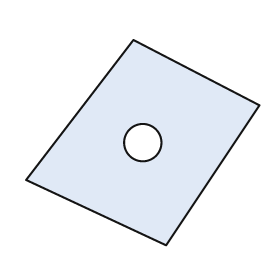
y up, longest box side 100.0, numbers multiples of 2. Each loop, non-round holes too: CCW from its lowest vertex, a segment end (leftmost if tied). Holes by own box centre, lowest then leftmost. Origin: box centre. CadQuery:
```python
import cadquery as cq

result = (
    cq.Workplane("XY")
    .moveTo(10.0, -44.0)
    .lineTo(50.0, 16.0)
    .lineTo(-4.0, 44.0)
    .lineTo(-50.0, -16.0)
    .close()
    .moveTo(0.0, 0.0)
    .circle(8.0)
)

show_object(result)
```